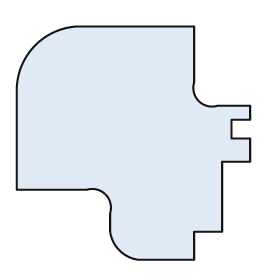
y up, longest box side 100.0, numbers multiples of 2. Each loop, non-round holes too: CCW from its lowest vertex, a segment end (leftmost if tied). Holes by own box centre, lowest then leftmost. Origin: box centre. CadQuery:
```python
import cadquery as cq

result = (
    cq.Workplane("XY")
    .moveTo(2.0, -50.0)
    .lineTo(26.0, -50.0)
    .lineTo(26.0, -38.0)
    .lineTo(38.0, -38.0)
    .lineTo(38.0, -8.0)
    .lineTo(50.0, -8.0)
    .lineTo(50.0, 2.0)
    .lineTo(42.0, 2.0)
    .lineTo(42.0, 10.0)
    .lineTo(50.0, 10.0)
    .lineTo(50.0, 16.0)
    .lineTo(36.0, 16.0)
    .threePointArc((28.0, 18.0), (26.0, 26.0))
    .lineTo(26.0, 50.0)
    .lineTo(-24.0, 50.0)
    .threePointArc((-42.0, 42.0), (-50.0, 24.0))
    .lineTo(-50.0, -20.0)
    .lineTo(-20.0, -20.0)
    .threePointArc((-12.0, -22.0), (-10.0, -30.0))
    .lineTo(-10.0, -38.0)
    .threePointArc((-6.0, -46.0), (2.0, -50.0))
    .close()
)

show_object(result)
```